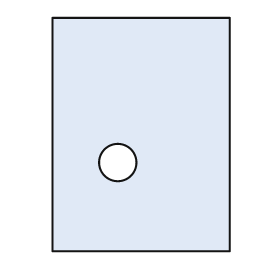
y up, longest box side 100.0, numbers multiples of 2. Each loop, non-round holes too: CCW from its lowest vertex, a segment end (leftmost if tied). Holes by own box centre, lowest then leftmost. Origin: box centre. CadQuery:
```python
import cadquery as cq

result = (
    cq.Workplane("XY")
    .moveTo(-38.0, -50.0)
    .lineTo(38.0, -50.0)
    .lineTo(38.0, 50.0)
    .lineTo(-38.0, 50.0)
    .close()
    .moveTo(-10.0, -12.0)
    .circle(8.0)
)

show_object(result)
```